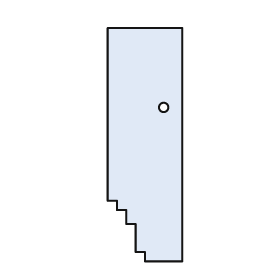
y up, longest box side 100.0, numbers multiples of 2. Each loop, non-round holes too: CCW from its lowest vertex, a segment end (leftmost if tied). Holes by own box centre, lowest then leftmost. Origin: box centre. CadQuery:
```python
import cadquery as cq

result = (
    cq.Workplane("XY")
    .moveTo(0.0, -50.0)
    .lineTo(16.0, -50.0)
    .lineTo(16.0, 50.0)
    .lineTo(-16.0, 50.0)
    .lineTo(-16.0, -24.0)
    .lineTo(-12.0, -24.0)
    .lineTo(-12.0, -28.0)
    .lineTo(-8.0, -28.0)
    .lineTo(-8.0, -34.0)
    .lineTo(-4.0, -34.0)
    .lineTo(-4.0, -46.0)
    .lineTo(0.0, -46.0)
    .close()
    .moveTo(8.0, 16.0)
    .circle(2.0)
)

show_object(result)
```